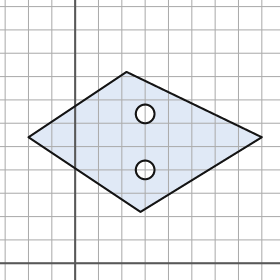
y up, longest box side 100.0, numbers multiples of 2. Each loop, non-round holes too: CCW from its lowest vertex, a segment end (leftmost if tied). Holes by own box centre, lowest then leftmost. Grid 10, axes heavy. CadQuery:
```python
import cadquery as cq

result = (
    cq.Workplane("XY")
    .moveTo(28.0, 22.0)
    .lineTo(80.0, 54.0)
    .lineTo(22.0, 82.0)
    .lineTo(-20.0, 54.0)
    .close()
    .moveTo(30.0, 40.0)
    .circle(4.0)
    .moveTo(30.0, 64.0)
    .circle(4.0)
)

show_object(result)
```